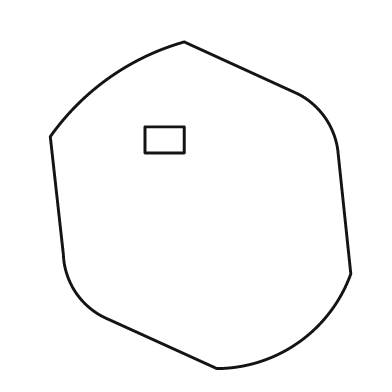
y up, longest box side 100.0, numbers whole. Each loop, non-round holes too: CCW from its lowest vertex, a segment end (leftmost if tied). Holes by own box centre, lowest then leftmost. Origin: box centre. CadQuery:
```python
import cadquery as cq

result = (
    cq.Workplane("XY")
    .moveTo(5.0, -50.0)
    .threePointArc((30.0, -42.0), (46.0, -21.0))
    .lineTo(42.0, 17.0)
    .threePointArc((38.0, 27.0), (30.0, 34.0))
    .lineTo(-5.0, 50.0)
    .threePointArc((-28.0, 39.0), (-46.0, 21.0))
    .lineTo(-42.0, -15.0)
    .threePointArc((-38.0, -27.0), (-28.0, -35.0))
    .close()
    .moveTo(-17.0, 16.0)
    .lineTo(-5.0, 16.0)
    .lineTo(-5.0, 24.0)
    .lineTo(-17.0, 24.0)
    .close()
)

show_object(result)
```